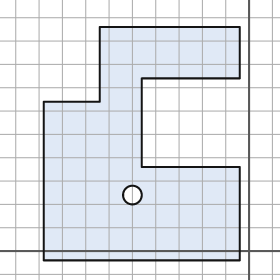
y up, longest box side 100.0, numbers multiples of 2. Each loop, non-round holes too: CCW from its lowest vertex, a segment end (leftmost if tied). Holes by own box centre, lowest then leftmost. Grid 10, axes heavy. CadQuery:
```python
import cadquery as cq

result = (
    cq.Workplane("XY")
    .moveTo(-88.0, -4.0)
    .lineTo(-4.0, -4.0)
    .lineTo(-4.0, 36.0)
    .lineTo(-46.0, 36.0)
    .lineTo(-46.0, 74.0)
    .lineTo(-4.0, 74.0)
    .lineTo(-4.0, 96.0)
    .lineTo(-64.0, 96.0)
    .lineTo(-64.0, 64.0)
    .lineTo(-88.0, 64.0)
    .close()
    .moveTo(-50.0, 24.0)
    .circle(4.0)
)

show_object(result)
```